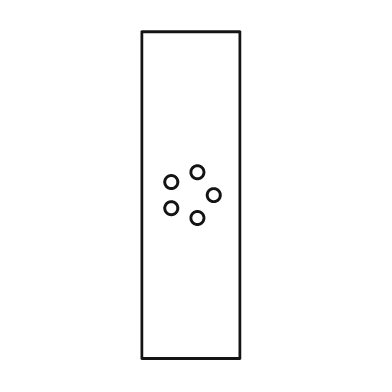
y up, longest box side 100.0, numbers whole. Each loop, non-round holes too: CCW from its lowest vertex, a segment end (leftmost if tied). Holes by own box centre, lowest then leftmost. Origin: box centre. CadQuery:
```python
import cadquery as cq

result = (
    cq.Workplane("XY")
    .moveTo(-15.0, -50.0)
    .lineTo(15.0, -50.0)
    .lineTo(15.0, 50.0)
    .lineTo(-15.0, 50.0)
    .close()
    .moveTo(2.0, -7.0)
    .circle(2.0)
    .moveTo(-6.0, -4.0)
    .circle(2.0)
    .moveTo(7.0, 0.0)
    .circle(2.0)
    .moveTo(-6.0, 4.0)
    .circle(2.0)
    .moveTo(2.0, 7.0)
    .circle(2.0)
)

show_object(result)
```